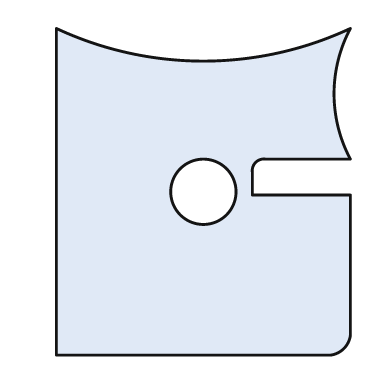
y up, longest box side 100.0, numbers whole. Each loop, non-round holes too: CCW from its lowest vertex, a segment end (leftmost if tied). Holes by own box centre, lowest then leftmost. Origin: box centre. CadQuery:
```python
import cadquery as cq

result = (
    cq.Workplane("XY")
    .moveTo(-45.0, -50.0)
    .lineTo(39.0, -50.0)
    .threePointArc((43.0, -48.0), (45.0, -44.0))
    .lineTo(45.0, -1.0)
    .lineTo(15.0, -1.0)
    .lineTo(15.0, 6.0)
    .threePointArc((16.0, 9.0), (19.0, 10.0))
    .lineTo(45.0, 10.0)
    .threePointArc((40.0, 30.0), (45.0, 50.0))
    .threePointArc((0.0, 40.0), (-45.0, 50.0))
    .close()
    .moveTo(0.0, 0.0)
    .circle(10.0)
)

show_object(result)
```